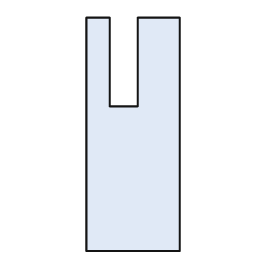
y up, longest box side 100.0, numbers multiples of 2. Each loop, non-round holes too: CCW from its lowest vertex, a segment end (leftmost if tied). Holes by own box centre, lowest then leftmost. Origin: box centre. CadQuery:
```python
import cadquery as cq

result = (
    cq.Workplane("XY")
    .moveTo(-20.0, -50.0)
    .lineTo(20.0, -50.0)
    .lineTo(20.0, 50.0)
    .lineTo(2.0, 50.0)
    .lineTo(2.0, 12.0)
    .lineTo(-10.0, 12.0)
    .lineTo(-10.0, 50.0)
    .lineTo(-20.0, 50.0)
    .close()
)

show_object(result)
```